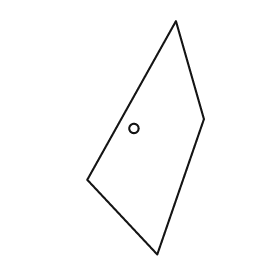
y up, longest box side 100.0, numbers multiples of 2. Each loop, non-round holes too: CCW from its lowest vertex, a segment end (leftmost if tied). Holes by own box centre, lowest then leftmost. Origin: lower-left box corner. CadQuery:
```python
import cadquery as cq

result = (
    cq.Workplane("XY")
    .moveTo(30.0, 0.0)
    .lineTo(50.0, 58.0)
    .lineTo(38.0, 100.0)
    .lineTo(0.0, 32.0)
    .close()
    .moveTo(20.0, 54.0)
    .circle(2.0)
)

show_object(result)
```